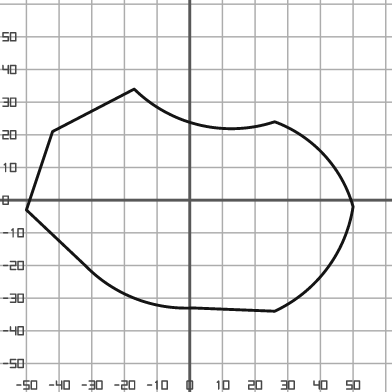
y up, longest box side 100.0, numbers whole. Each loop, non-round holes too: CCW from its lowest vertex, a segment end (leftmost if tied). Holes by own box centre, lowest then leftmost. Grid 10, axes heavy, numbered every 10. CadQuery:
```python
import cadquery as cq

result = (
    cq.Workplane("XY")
    .moveTo(26.0, -34.0)
    .threePointArc((42.0, -21.0), (50.0, -2.0))
    .threePointArc((41.0, 14.0), (26.0, 24.0))
    .threePointArc((3.0, 23.0), (-17.0, 34.0))
    .lineTo(-42.0, 21.0)
    .lineTo(-50.0, -3.0)
    .lineTo(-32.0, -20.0)
    .threePointArc((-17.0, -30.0), (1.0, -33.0))
    .close()
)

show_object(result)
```